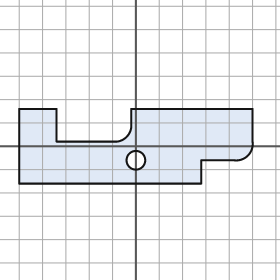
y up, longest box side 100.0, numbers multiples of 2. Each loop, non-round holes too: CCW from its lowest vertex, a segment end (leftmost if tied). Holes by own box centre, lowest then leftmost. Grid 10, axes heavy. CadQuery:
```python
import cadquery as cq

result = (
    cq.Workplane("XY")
    .moveTo(-50.0, -16.0)
    .lineTo(28.0, -16.0)
    .lineTo(28.0, -6.0)
    .lineTo(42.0, -6.0)
    .threePointArc((48.0, -4.0), (50.0, 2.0))
    .lineTo(50.0, 16.0)
    .lineTo(-2.0, 16.0)
    .lineTo(-2.0, 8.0)
    .threePointArc((-4.0, 4.0), (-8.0, 2.0))
    .lineTo(-34.0, 2.0)
    .lineTo(-34.0, 16.0)
    .lineTo(-50.0, 16.0)
    .close()
    .moveTo(0.0, -6.0)
    .circle(4.0)
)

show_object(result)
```